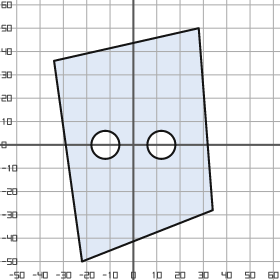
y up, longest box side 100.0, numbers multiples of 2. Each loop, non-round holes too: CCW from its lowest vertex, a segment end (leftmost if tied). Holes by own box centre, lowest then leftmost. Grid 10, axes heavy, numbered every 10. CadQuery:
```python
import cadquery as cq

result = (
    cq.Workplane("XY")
    .moveTo(-22.0, -50.0)
    .lineTo(34.0, -28.0)
    .lineTo(28.0, 50.0)
    .lineTo(-34.0, 36.0)
    .close()
    .moveTo(-12.0, 0.0)
    .circle(6.0)
    .moveTo(12.0, 0.0)
    .circle(6.0)
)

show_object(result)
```